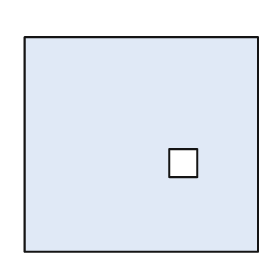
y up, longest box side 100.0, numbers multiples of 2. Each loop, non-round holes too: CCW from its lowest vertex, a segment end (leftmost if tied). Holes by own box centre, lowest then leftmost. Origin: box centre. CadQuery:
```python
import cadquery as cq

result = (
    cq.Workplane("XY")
    .moveTo(-50.0, -46.0)
    .lineTo(50.0, -46.0)
    .lineTo(50.0, 46.0)
    .lineTo(-50.0, 46.0)
    .close()
    .moveTo(12.0, -14.0)
    .lineTo(24.0, -14.0)
    .lineTo(24.0, -2.0)
    .lineTo(12.0, -2.0)
    .close()
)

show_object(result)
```